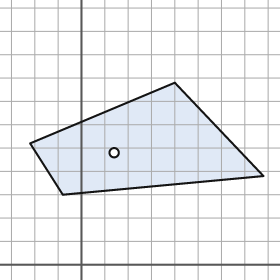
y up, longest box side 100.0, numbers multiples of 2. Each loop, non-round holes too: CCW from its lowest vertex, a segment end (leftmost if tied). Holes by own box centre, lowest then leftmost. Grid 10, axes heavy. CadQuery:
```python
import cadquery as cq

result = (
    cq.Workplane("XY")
    .moveTo(-8.0, 30.0)
    .lineTo(78.0, 38.0)
    .lineTo(40.0, 78.0)
    .lineTo(-22.0, 52.0)
    .close()
    .moveTo(14.0, 48.0)
    .circle(2.0)
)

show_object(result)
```